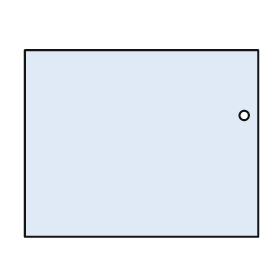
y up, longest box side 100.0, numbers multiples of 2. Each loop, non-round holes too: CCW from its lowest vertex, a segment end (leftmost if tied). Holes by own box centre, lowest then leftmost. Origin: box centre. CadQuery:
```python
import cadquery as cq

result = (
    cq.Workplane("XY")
    .moveTo(-50.0, -40.0)
    .lineTo(50.0, -40.0)
    .lineTo(50.0, 40.0)
    .lineTo(-50.0, 40.0)
    .close()
    .moveTo(44.0, 12.0)
    .circle(2.0)
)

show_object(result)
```